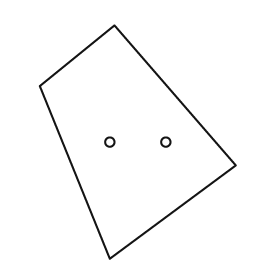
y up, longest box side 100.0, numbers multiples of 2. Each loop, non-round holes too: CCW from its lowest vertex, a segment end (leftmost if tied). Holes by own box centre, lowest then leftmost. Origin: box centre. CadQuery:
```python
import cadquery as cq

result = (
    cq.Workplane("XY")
    .moveTo(-12.0, -50.0)
    .lineTo(42.0, -10.0)
    .lineTo(-10.0, 50.0)
    .lineTo(-42.0, 24.0)
    .close()
    .moveTo(-12.0, 0.0)
    .circle(2.0)
    .moveTo(12.0, 0.0)
    .circle(2.0)
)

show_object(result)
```